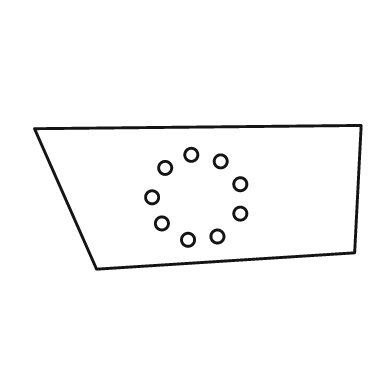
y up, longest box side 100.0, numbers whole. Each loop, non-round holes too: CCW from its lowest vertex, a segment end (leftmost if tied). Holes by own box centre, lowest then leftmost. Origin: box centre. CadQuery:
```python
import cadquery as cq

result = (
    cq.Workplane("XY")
    .moveTo(-31.0, -22.0)
    .lineTo(48.0, -17.0)
    .lineTo(50.0, 22.0)
    .lineTo(-50.0, 21.0)
    .close()
    .moveTo(-3.0, -13.0)
    .circle(2.0)
    .moveTo(6.0, -12.0)
    .circle(2.0)
    .moveTo(-11.0, -8.0)
    .circle(2.0)
    .moveTo(13.0, -5.0)
    .circle(2.0)
    .moveTo(-14.0, 0.0)
    .circle(2.0)
    .moveTo(13.0, 4.0)
    .circle(2.0)
    .moveTo(-10.0, 9.0)
    .circle(2.0)
    .moveTo(7.0, 11.0)
    .circle(2.0)
    .moveTo(-2.0, 13.0)
    .circle(2.0)
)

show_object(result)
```